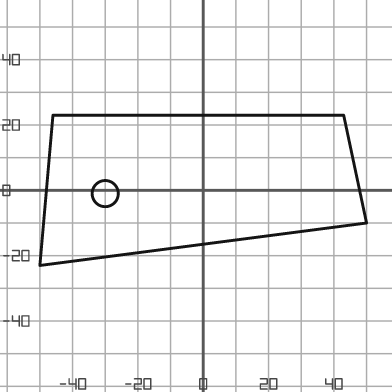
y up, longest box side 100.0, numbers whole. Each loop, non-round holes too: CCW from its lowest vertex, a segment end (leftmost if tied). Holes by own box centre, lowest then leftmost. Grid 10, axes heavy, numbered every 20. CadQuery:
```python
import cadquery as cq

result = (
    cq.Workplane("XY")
    .moveTo(-50.0, -23.0)
    .lineTo(50.0, -10.0)
    .lineTo(43.0, 23.0)
    .lineTo(-46.0, 23.0)
    .close()
    .moveTo(-30.0, -1.0)
    .circle(4.0)
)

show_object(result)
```